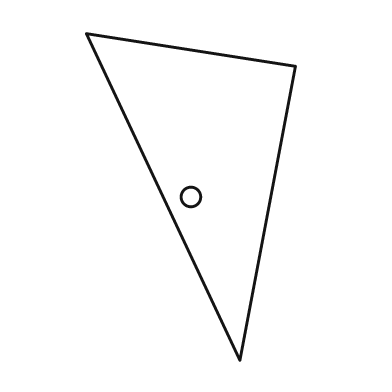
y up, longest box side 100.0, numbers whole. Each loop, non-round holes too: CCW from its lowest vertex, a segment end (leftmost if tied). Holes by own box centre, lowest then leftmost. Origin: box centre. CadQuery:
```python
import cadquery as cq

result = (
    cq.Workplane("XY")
    .moveTo(15.0, -50.0)
    .lineTo(32.0, 40.0)
    .lineTo(-32.0, 50.0)
    .close()
    .moveTo(0.0, 0.0)
    .circle(3.0)
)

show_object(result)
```